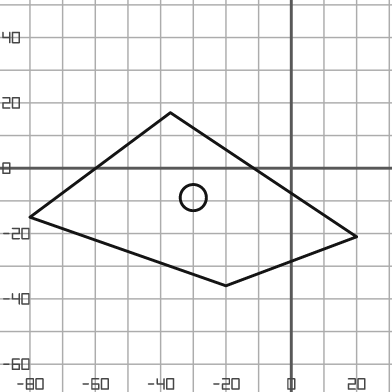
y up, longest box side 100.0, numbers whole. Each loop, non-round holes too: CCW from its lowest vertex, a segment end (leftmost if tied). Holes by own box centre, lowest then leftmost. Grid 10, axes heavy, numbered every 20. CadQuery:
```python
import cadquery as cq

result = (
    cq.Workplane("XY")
    .moveTo(-20.0, -36.0)
    .lineTo(20.0, -21.0)
    .lineTo(-37.0, 17.0)
    .lineTo(-80.0, -15.0)
    .close()
    .moveTo(-30.0, -9.0)
    .circle(4.0)
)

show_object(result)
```